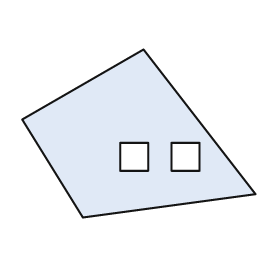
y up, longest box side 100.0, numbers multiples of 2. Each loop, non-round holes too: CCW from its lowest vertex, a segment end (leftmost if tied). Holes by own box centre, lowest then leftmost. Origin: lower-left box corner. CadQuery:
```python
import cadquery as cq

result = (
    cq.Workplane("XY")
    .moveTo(26.0, 0.0)
    .lineTo(100.0, 10.0)
    .lineTo(52.0, 72.0)
    .lineTo(0.0, 42.0)
    .close()
    .moveTo(42.0, 20.0)
    .lineTo(54.0, 20.0)
    .lineTo(54.0, 32.0)
    .lineTo(42.0, 32.0)
    .close()
    .moveTo(64.0, 20.0)
    .lineTo(76.0, 20.0)
    .lineTo(76.0, 32.0)
    .lineTo(64.0, 32.0)
    .close()
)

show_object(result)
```